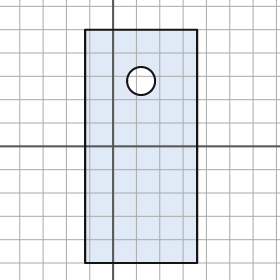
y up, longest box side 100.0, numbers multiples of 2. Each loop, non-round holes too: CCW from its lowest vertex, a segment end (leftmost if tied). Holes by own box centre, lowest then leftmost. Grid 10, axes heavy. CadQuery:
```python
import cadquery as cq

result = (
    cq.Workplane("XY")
    .moveTo(-12.0, -50.0)
    .lineTo(36.0, -50.0)
    .lineTo(36.0, 50.0)
    .lineTo(-12.0, 50.0)
    .close()
    .moveTo(12.0, 28.0)
    .circle(6.0)
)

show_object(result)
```